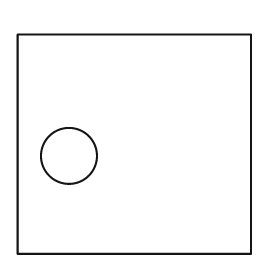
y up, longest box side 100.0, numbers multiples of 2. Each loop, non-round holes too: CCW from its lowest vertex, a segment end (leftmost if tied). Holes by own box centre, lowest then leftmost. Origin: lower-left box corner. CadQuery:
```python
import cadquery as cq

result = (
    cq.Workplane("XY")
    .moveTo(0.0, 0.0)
    .lineTo(100.0, 0.0)
    .lineTo(100.0, 94.0)
    .lineTo(0.0, 94.0)
    .close()
    .moveTo(22.0, 42.0)
    .circle(12.0)
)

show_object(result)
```